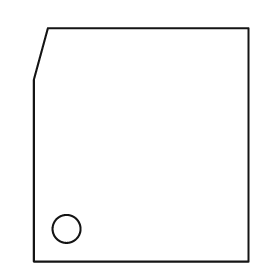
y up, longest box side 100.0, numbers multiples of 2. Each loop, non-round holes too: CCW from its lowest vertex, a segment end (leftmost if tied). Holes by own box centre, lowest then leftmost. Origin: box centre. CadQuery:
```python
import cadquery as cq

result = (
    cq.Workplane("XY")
    .moveTo(-46.0, -50.0)
    .lineTo(46.0, -50.0)
    .lineTo(46.0, 50.0)
    .lineTo(-40.0, 50.0)
    .lineTo(-46.0, 28.0)
    .close()
    .moveTo(-32.0, -36.0)
    .circle(6.0)
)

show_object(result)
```